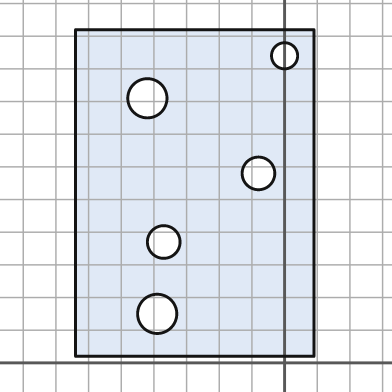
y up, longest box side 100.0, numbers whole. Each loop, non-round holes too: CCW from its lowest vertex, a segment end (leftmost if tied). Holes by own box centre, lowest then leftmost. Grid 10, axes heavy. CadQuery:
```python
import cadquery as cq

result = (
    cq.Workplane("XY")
    .moveTo(-64.0, 2.0)
    .lineTo(9.0, 2.0)
    .lineTo(9.0, 102.0)
    .lineTo(-64.0, 102.0)
    .close()
    .moveTo(-39.0, 15.0)
    .circle(6.0)
    .moveTo(-37.0, 37.0)
    .circle(5.0)
    .moveTo(-8.0, 58.0)
    .circle(5.0)
    .moveTo(-42.0, 81.0)
    .circle(6.0)
    .moveTo(0.0, 94.0)
    .circle(4.0)
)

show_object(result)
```